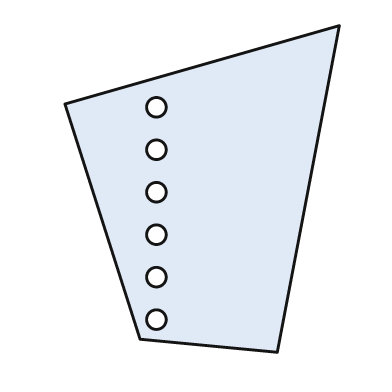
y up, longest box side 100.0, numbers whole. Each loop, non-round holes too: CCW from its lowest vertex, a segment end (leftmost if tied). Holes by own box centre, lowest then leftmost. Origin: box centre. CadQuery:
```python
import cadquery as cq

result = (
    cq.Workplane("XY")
    .moveTo(23.0, -50.0)
    .lineTo(42.0, 50.0)
    .lineTo(-42.0, 26.0)
    .lineTo(-19.0, -46.0)
    .close()
    .moveTo(-14.0, -40.0)
    .circle(3.0)
    .moveTo(-14.0, -27.0)
    .circle(3.0)
    .moveTo(-14.0, -14.0)
    .circle(3.0)
    .moveTo(-14.0, -1.0)
    .circle(3.0)
    .moveTo(-14.0, 12.0)
    .circle(3.0)
    .moveTo(-14.0, 25.0)
    .circle(3.0)
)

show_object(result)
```